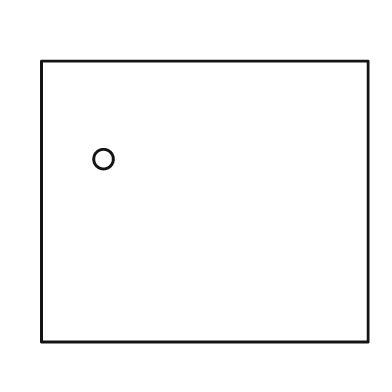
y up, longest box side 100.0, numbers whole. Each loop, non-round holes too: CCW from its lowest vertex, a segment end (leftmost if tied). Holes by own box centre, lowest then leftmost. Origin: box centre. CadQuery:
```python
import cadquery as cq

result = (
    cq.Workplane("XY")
    .moveTo(-50.0, -43.0)
    .lineTo(50.0, -43.0)
    .lineTo(50.0, 43.0)
    .lineTo(-50.0, 43.0)
    .close()
    .moveTo(-31.0, 13.0)
    .circle(3.0)
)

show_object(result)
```